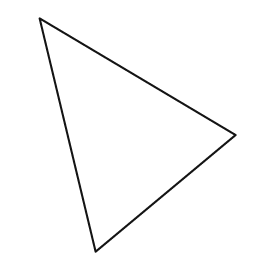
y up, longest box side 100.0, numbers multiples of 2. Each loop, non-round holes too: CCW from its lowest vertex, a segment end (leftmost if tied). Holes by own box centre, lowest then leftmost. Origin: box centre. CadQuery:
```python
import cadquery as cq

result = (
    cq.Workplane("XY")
    .moveTo(-18.0, -50.0)
    .lineTo(42.0, 0.0)
    .lineTo(-42.0, 50.0)
    .close()
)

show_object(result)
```